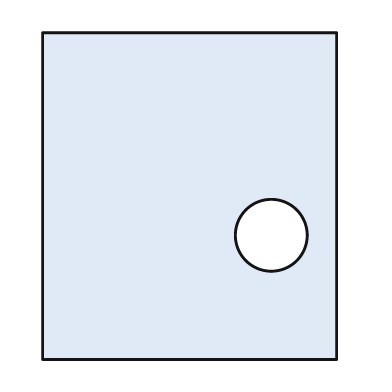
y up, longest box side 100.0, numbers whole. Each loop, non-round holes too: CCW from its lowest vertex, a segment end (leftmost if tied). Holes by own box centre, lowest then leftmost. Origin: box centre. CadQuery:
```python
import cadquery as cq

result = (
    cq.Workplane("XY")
    .moveTo(-45.0, -50.0)
    .lineTo(45.0, -50.0)
    .lineTo(45.0, 50.0)
    .lineTo(-45.0, 50.0)
    .close()
    .moveTo(25.0, -12.0)
    .circle(11.0)
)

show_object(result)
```